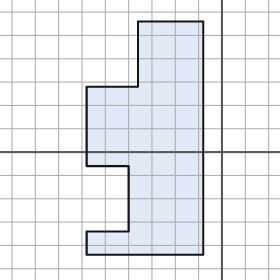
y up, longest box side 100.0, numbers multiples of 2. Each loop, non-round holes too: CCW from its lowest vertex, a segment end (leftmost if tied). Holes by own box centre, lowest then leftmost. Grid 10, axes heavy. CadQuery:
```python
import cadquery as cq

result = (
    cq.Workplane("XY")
    .moveTo(-58.0, -44.0)
    .lineTo(-8.0, -44.0)
    .lineTo(-8.0, 56.0)
    .lineTo(-36.0, 56.0)
    .lineTo(-36.0, 28.0)
    .lineTo(-58.0, 28.0)
    .lineTo(-58.0, -6.0)
    .lineTo(-40.0, -6.0)
    .lineTo(-40.0, -34.0)
    .lineTo(-58.0, -34.0)
    .close()
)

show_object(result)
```